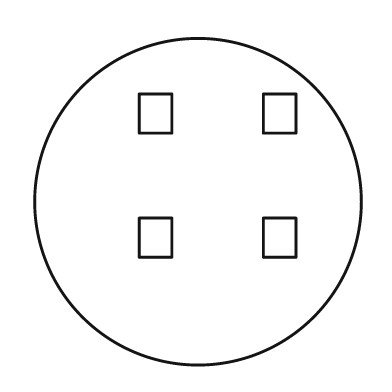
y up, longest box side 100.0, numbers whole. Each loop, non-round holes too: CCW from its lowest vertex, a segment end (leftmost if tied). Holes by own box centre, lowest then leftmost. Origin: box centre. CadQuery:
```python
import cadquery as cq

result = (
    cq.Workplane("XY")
    .moveTo(0.0, 0.0)
    .circle(50.0)
    .moveTo(-18.0, -17.0)
    .lineTo(-8.0, -17.0)
    .lineTo(-8.0, -5.0)
    .lineTo(-18.0, -5.0)
    .close()
    .moveTo(20.0, -17.0)
    .lineTo(30.0, -17.0)
    .lineTo(30.0, -5.0)
    .lineTo(20.0, -5.0)
    .close()
    .moveTo(-18.0, 21.0)
    .lineTo(-8.0, 21.0)
    .lineTo(-8.0, 33.0)
    .lineTo(-18.0, 33.0)
    .close()
    .moveTo(20.0, 21.0)
    .lineTo(30.0, 21.0)
    .lineTo(30.0, 33.0)
    .lineTo(20.0, 33.0)
    .close()
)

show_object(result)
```